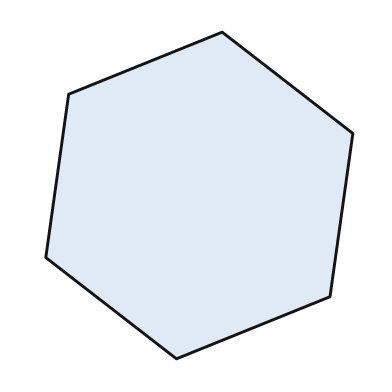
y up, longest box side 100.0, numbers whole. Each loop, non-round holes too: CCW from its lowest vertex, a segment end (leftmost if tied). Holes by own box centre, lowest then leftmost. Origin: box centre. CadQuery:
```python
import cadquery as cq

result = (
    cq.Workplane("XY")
    .moveTo(-7.0, -50.0)
    .lineTo(40.0, -31.0)
    .lineTo(47.0, 19.0)
    .lineTo(7.0, 50.0)
    .lineTo(-40.0, 31.0)
    .lineTo(-47.0, -19.0)
    .close()
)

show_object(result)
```